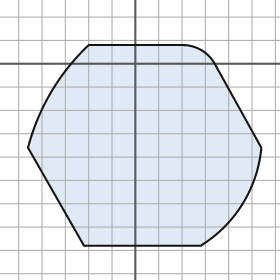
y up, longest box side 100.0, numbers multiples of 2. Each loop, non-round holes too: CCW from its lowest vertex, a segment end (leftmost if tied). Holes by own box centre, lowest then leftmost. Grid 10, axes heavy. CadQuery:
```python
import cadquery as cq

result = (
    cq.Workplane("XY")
    .moveTo(-22.0, -78.0)
    .lineTo(28.0, -78.0)
    .threePointArc((46.0, -60.0), (54.0, -36.0))
    .lineTo(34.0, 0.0)
    .threePointArc((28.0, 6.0), (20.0, 8.0))
    .lineTo(-20.0, 8.0)
    .threePointArc((-36.0, -12.0), (-46.0, -36.0))
    .close()
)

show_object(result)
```